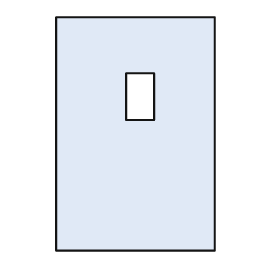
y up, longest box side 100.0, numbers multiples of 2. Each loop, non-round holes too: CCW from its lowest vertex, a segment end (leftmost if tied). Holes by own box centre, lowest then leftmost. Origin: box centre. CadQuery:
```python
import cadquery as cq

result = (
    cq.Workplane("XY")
    .moveTo(-34.0, -50.0)
    .lineTo(34.0, -50.0)
    .lineTo(34.0, 50.0)
    .lineTo(-34.0, 50.0)
    .close()
    .moveTo(-4.0, 6.0)
    .lineTo(8.0, 6.0)
    .lineTo(8.0, 26.0)
    .lineTo(-4.0, 26.0)
    .close()
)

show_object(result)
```